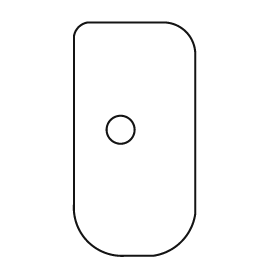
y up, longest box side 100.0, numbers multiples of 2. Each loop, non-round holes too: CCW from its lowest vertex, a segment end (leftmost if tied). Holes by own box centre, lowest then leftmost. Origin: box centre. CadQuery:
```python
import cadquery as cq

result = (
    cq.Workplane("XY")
    .moveTo(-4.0, -50.0)
    .lineTo(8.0, -50.0)
    .threePointArc((20.0, -44.0), (26.0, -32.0))
    .lineTo(26.0, 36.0)
    .threePointArc((22.0, 46.0), (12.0, 50.0))
    .lineTo(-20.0, 50.0)
    .threePointArc((-24.0, 48.0), (-26.0, 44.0))
    .lineTo(-26.0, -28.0)
    .threePointArc((-20.0, -44.0), (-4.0, -50.0))
    .close()
    .moveTo(-6.0, 4.0)
    .circle(6.0)
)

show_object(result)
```